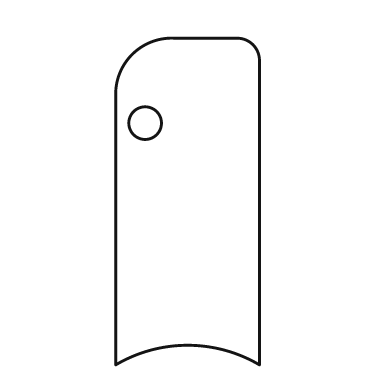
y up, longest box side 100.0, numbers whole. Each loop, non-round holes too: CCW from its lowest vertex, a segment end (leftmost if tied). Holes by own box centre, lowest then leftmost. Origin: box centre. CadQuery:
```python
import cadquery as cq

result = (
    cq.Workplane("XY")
    .moveTo(-22.0, -50.0)
    .threePointArc((0.0, -44.0), (22.0, -50.0))
    .lineTo(22.0, 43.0)
    .threePointArc((20.0, 48.0), (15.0, 50.0))
    .lineTo(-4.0, 50.0)
    .threePointArc((-17.0, 45.0), (-22.0, 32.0))
    .close()
    .moveTo(-13.0, 24.0)
    .circle(5.0)
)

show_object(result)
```